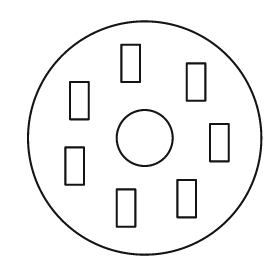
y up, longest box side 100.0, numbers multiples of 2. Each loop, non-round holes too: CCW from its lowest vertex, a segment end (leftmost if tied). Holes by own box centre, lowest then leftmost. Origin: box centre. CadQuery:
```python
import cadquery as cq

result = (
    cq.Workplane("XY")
    .moveTo(0.0, 0.0)
    .circle(50.0)
    .moveTo(-12.0, -38.0)
    .lineTo(-4.0, -38.0)
    .lineTo(-4.0, -22.0)
    .lineTo(-12.0, -22.0)
    .close()
    .moveTo(14.0, -34.0)
    .lineTo(22.0, -34.0)
    .lineTo(22.0, -18.0)
    .lineTo(14.0, -18.0)
    .close()
    .moveTo(-34.0, -20.0)
    .lineTo(-26.0, -20.0)
    .lineTo(-26.0, -4.0)
    .lineTo(-34.0, -4.0)
    .close()
    .moveTo(28.0, -10.0)
    .lineTo(36.0, -10.0)
    .lineTo(36.0, 6.0)
    .lineTo(28.0, 6.0)
    .close()
    .moveTo(0.0, 0.0)
    .circle(12.0)
    .moveTo(-32.0, 8.0)
    .lineTo(-24.0, 8.0)
    .lineTo(-24.0, 24.0)
    .lineTo(-32.0, 24.0)
    .close()
    .moveTo(18.0, 16.0)
    .lineTo(26.0, 16.0)
    .lineTo(26.0, 32.0)
    .lineTo(18.0, 32.0)
    .close()
    .moveTo(-10.0, 24.0)
    .lineTo(-2.0, 24.0)
    .lineTo(-2.0, 40.0)
    .lineTo(-10.0, 40.0)
    .close()
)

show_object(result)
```